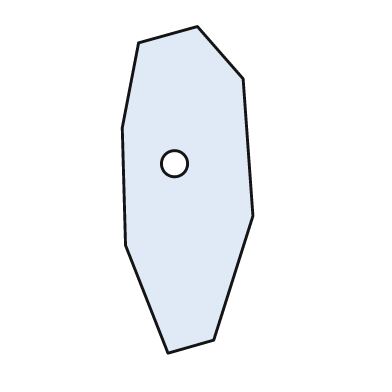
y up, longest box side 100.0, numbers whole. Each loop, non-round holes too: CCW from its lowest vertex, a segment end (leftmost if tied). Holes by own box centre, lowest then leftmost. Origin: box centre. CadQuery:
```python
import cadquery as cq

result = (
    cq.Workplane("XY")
    .moveTo(-6.0, -50.0)
    .lineTo(8.0, -46.0)
    .lineTo(20.0, -8.0)
    .lineTo(17.0, 34.0)
    .lineTo(3.0, 50.0)
    .lineTo(-15.0, 45.0)
    .lineTo(-20.0, 19.0)
    .lineTo(-19.0, -17.0)
    .close()
    .moveTo(-4.0, 8.0)
    .circle(4.0)
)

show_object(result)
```